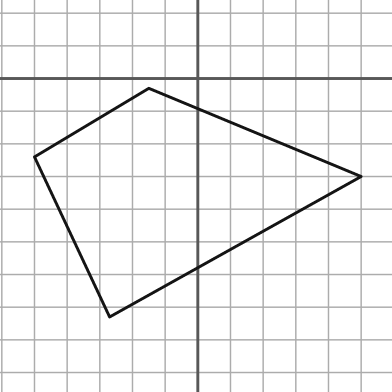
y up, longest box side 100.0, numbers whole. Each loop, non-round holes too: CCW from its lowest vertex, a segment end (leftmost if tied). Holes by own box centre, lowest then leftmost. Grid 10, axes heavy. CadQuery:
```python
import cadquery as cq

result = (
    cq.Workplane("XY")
    .moveTo(-27.0, -73.0)
    .lineTo(50.0, -30.0)
    .lineTo(-15.0, -3.0)
    .lineTo(-50.0, -24.0)
    .close()
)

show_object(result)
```